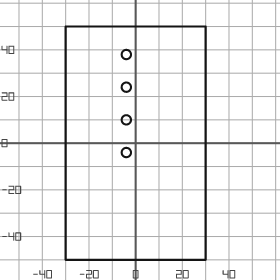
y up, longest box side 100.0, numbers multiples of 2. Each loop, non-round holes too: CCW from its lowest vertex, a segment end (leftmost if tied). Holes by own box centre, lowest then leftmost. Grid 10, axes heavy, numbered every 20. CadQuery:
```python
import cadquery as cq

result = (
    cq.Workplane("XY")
    .moveTo(-30.0, -50.0)
    .lineTo(30.0, -50.0)
    .lineTo(30.0, 50.0)
    .lineTo(-30.0, 50.0)
    .close()
    .moveTo(-4.0, -4.0)
    .circle(2.0)
    .moveTo(-4.0, 10.0)
    .circle(2.0)
    .moveTo(-4.0, 24.0)
    .circle(2.0)
    .moveTo(-4.0, 38.0)
    .circle(2.0)
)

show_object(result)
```